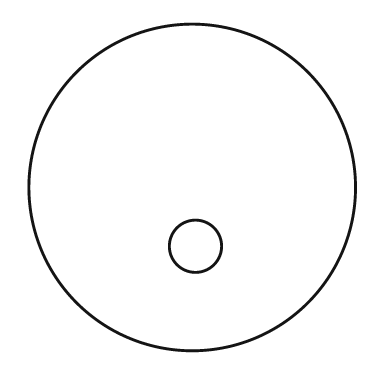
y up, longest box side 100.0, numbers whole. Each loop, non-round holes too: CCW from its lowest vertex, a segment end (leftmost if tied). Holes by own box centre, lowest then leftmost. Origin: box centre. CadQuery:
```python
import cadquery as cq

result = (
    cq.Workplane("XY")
    .moveTo(0.0, 0.0)
    .circle(50.0)
    .moveTo(1.0, -18.0)
    .circle(8.0)
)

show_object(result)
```